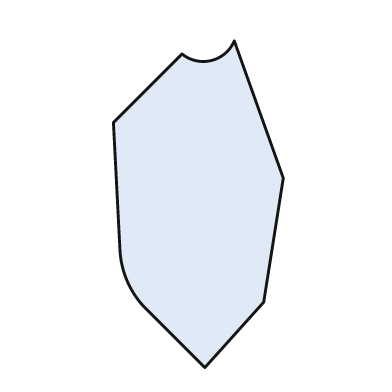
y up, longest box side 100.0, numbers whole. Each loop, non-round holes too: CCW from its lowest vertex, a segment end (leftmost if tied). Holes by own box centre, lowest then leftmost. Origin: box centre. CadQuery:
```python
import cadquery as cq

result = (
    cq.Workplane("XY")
    .moveTo(2.0, -50.0)
    .lineTo(20.0, -30.0)
    .lineTo(26.0, 8.0)
    .lineTo(11.0, 50.0)
    .threePointArc((4.0, 44.0), (-5.0, 46.0))
    .lineTo(-26.0, 25.0)
    .lineTo(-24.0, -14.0)
    .threePointArc((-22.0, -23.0), (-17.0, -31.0))
    .close()
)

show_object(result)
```